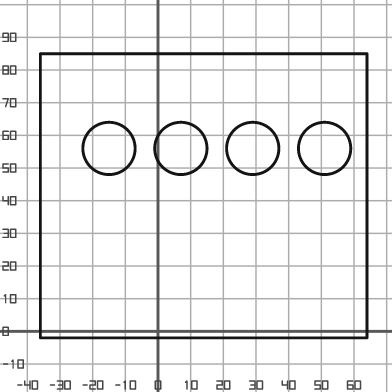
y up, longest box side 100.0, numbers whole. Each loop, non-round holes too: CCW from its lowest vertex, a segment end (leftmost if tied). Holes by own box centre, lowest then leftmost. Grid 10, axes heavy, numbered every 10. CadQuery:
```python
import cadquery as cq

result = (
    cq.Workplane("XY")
    .moveTo(-36.0, -2.0)
    .lineTo(64.0, -2.0)
    .lineTo(64.0, 85.0)
    .lineTo(-36.0, 85.0)
    .close()
    .moveTo(-15.0, 56.0)
    .circle(8.0)
    .moveTo(7.0, 56.0)
    .circle(8.0)
    .moveTo(29.0, 56.0)
    .circle(8.0)
    .moveTo(51.0, 56.0)
    .circle(8.0)
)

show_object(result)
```